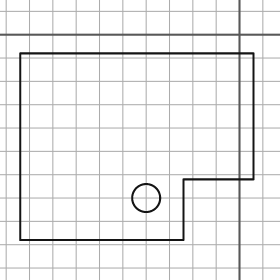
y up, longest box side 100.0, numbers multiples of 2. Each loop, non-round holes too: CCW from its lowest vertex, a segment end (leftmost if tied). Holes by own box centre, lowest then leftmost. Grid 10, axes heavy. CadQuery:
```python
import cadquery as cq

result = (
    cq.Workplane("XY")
    .moveTo(-94.0, -88.0)
    .lineTo(-24.0, -88.0)
    .lineTo(-24.0, -62.0)
    .lineTo(6.0, -62.0)
    .lineTo(6.0, -8.0)
    .lineTo(-94.0, -8.0)
    .close()
    .moveTo(-40.0, -70.0)
    .circle(6.0)
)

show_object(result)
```